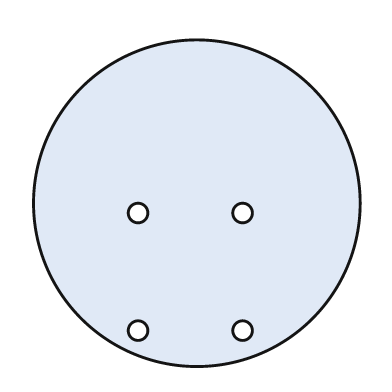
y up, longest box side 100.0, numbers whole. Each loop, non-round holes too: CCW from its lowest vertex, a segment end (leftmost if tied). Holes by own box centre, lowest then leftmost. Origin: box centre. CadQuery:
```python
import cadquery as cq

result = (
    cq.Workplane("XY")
    .moveTo(0.0, 0.0)
    .circle(50.0)
    .moveTo(-18.0, -39.0)
    .circle(3.0)
    .moveTo(14.0, -39.0)
    .circle(3.0)
    .moveTo(-18.0, -3.0)
    .circle(3.0)
    .moveTo(14.0, -3.0)
    .circle(3.0)
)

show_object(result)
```